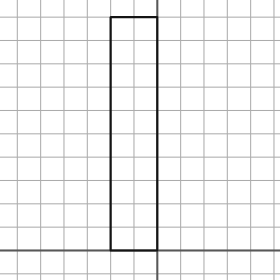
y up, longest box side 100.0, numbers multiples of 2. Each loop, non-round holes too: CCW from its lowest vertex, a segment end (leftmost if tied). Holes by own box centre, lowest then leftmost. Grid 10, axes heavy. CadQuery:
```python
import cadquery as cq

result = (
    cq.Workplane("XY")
    .moveTo(-20.0, 0.0)
    .lineTo(0.0, 0.0)
    .lineTo(0.0, 100.0)
    .lineTo(-20.0, 100.0)
    .close()
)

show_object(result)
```